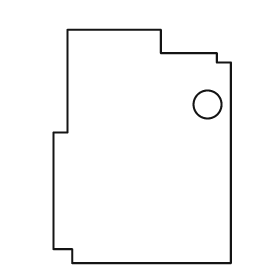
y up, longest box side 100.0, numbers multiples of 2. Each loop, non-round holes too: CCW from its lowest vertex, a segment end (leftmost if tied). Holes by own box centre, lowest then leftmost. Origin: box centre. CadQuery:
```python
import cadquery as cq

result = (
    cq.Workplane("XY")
    .moveTo(-30.0, -50.0)
    .lineTo(38.0, -50.0)
    .lineTo(38.0, 36.0)
    .lineTo(32.0, 36.0)
    .lineTo(32.0, 40.0)
    .lineTo(8.0, 40.0)
    .lineTo(8.0, 50.0)
    .lineTo(-32.0, 50.0)
    .lineTo(-32.0, 6.0)
    .lineTo(-38.0, 6.0)
    .lineTo(-38.0, -44.0)
    .lineTo(-30.0, -44.0)
    .close()
    .moveTo(28.0, 18.0)
    .circle(6.0)
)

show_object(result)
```